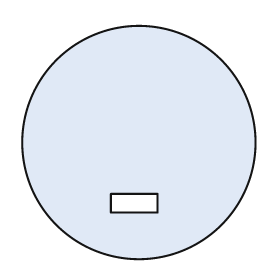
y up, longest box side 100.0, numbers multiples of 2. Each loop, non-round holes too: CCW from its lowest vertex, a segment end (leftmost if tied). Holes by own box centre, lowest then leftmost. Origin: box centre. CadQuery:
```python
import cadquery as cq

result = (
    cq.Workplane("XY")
    .moveTo(0.0, 0.0)
    .circle(50.0)
    .moveTo(-12.0, -30.0)
    .lineTo(8.0, -30.0)
    .lineTo(8.0, -22.0)
    .lineTo(-12.0, -22.0)
    .close()
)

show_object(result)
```